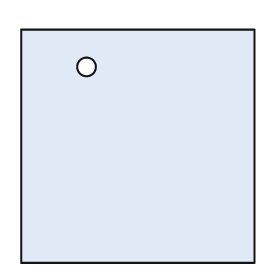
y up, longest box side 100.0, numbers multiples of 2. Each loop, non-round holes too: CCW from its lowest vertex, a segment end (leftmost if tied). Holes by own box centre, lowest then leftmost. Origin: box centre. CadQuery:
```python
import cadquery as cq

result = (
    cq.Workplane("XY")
    .moveTo(-50.0, -50.0)
    .lineTo(50.0, -50.0)
    .lineTo(50.0, 50.0)
    .lineTo(-50.0, 50.0)
    .close()
    .moveTo(-22.0, 34.0)
    .circle(4.0)
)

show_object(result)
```